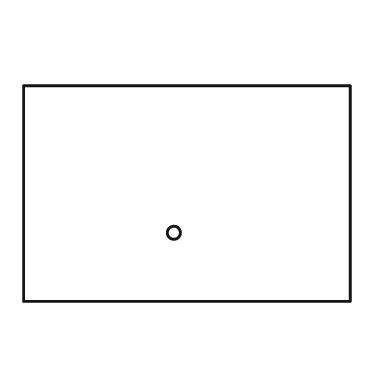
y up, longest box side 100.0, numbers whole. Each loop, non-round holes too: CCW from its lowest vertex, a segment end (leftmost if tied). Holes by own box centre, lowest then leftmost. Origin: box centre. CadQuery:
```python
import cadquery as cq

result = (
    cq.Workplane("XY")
    .moveTo(-50.0, -33.0)
    .lineTo(50.0, -33.0)
    .lineTo(50.0, 33.0)
    .lineTo(-50.0, 33.0)
    .close()
    .moveTo(-4.0, -12.0)
    .circle(2.0)
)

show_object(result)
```